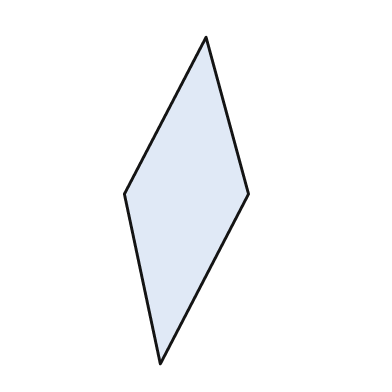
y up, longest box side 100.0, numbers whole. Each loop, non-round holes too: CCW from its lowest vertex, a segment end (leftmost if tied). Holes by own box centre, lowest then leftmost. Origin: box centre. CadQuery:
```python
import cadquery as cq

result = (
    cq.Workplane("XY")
    .moveTo(-8.0, -50.0)
    .lineTo(19.0, 2.0)
    .lineTo(6.0, 50.0)
    .lineTo(-19.0, 2.0)
    .close()
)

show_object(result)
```